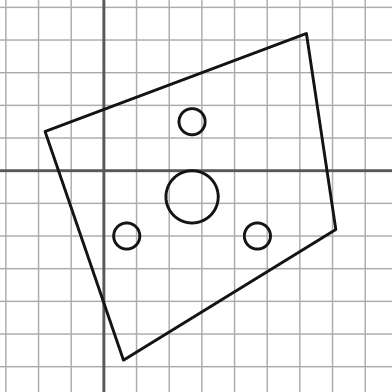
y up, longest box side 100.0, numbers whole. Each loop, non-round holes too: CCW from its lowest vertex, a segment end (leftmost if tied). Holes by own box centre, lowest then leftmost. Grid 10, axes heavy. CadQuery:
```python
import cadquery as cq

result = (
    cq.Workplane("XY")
    .moveTo(6.0, -58.0)
    .lineTo(71.0, -18.0)
    .lineTo(62.0, 42.0)
    .lineTo(-18.0, 12.0)
    .close()
    .moveTo(7.0, -20.0)
    .circle(4.0)
    .moveTo(47.0, -20.0)
    .circle(4.0)
    .moveTo(27.0, -8.0)
    .circle(8.0)
    .moveTo(27.0, 15.0)
    .circle(4.0)
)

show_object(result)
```